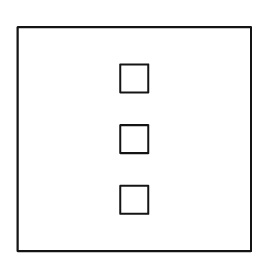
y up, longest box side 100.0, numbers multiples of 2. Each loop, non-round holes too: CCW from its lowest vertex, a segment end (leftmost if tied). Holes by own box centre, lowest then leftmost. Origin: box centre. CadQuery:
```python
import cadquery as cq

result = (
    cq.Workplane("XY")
    .moveTo(-50.0, -48.0)
    .lineTo(50.0, -48.0)
    .lineTo(50.0, 48.0)
    .lineTo(-50.0, 48.0)
    .close()
    .moveTo(-6.0, -32.0)
    .lineTo(6.0, -32.0)
    .lineTo(6.0, -20.0)
    .lineTo(-6.0, -20.0)
    .close()
    .moveTo(-6.0, -6.0)
    .lineTo(6.0, -6.0)
    .lineTo(6.0, 6.0)
    .lineTo(-6.0, 6.0)
    .close()
    .moveTo(-6.0, 20.0)
    .lineTo(6.0, 20.0)
    .lineTo(6.0, 32.0)
    .lineTo(-6.0, 32.0)
    .close()
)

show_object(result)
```